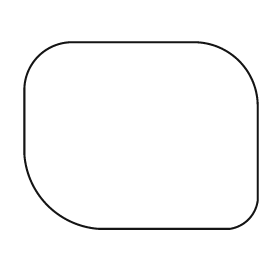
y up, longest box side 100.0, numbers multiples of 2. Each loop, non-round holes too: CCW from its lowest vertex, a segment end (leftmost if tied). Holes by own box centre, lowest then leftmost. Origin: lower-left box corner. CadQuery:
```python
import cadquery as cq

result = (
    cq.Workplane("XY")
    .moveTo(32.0, 0.0)
    .lineTo(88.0, 0.0)
    .threePointArc((96.0, 4.0), (100.0, 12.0))
    .lineTo(100.0, 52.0)
    .threePointArc((92.0, 72.0), (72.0, 80.0))
    .lineTo(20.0, 80.0)
    .threePointArc((6.0, 74.0), (0.0, 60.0))
    .lineTo(0.0, 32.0)
    .threePointArc((10.0, 10.0), (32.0, 0.0))
    .close()
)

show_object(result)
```